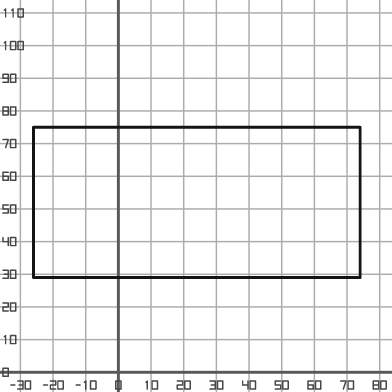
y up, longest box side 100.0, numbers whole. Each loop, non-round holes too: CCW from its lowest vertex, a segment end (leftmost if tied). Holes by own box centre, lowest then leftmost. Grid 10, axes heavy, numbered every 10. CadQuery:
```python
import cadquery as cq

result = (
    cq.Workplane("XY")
    .moveTo(-26.0, 29.0)
    .lineTo(74.0, 29.0)
    .lineTo(74.0, 75.0)
    .lineTo(-26.0, 75.0)
    .close()
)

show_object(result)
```